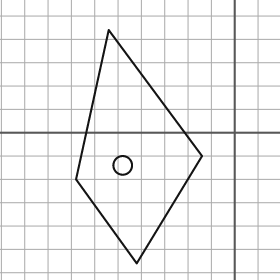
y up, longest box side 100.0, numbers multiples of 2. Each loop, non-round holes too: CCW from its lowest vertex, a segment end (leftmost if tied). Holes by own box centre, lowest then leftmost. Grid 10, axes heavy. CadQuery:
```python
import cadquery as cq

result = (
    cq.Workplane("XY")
    .moveTo(-42.0, -56.0)
    .lineTo(-14.0, -10.0)
    .lineTo(-54.0, 44.0)
    .lineTo(-68.0, -20.0)
    .close()
    .moveTo(-48.0, -14.0)
    .circle(4.0)
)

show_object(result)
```